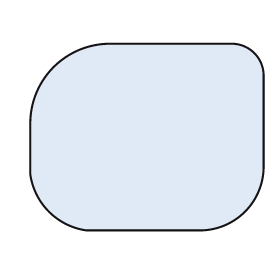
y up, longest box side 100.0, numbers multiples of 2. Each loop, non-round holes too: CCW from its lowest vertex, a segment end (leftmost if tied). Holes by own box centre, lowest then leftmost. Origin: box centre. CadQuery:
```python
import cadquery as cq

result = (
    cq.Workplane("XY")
    .moveTo(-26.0, -40.0)
    .lineTo(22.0, -40.0)
    .threePointArc((42.0, -32.0), (50.0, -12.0))
    .lineTo(50.0, 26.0)
    .threePointArc((46.0, 36.0), (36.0, 40.0))
    .lineTo(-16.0, 40.0)
    .threePointArc((-40.0, 30.0), (-50.0, 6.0))
    .lineTo(-50.0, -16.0)
    .threePointArc((-42.0, -32.0), (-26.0, -40.0))
    .close()
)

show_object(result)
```